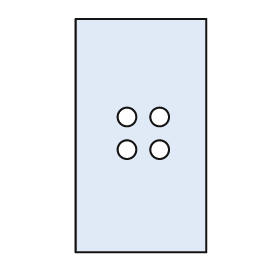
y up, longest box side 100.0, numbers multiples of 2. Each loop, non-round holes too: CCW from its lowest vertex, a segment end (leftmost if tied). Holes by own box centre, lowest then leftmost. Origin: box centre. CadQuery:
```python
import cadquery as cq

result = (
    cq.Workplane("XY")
    .moveTo(-28.0, -50.0)
    .lineTo(28.0, -50.0)
    .lineTo(28.0, 50.0)
    .lineTo(-28.0, 50.0)
    .close()
    .moveTo(-6.0, -6.0)
    .circle(4.0)
    .moveTo(8.0, -6.0)
    .circle(4.0)
    .moveTo(-6.0, 8.0)
    .circle(4.0)
    .moveTo(8.0, 8.0)
    .circle(4.0)
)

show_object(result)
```